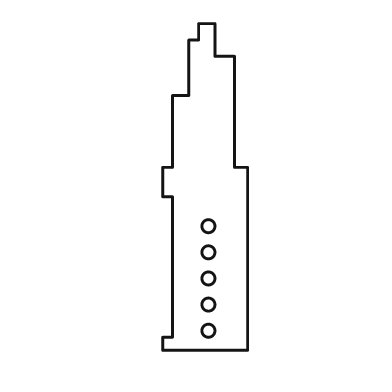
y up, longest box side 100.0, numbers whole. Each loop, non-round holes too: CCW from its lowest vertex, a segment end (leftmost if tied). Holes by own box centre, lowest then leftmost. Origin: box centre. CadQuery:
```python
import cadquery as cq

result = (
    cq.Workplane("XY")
    .moveTo(-13.0, -50.0)
    .lineTo(13.0, -50.0)
    .lineTo(13.0, 6.0)
    .lineTo(9.0, 6.0)
    .lineTo(9.0, 40.0)
    .lineTo(3.0, 40.0)
    .lineTo(3.0, 50.0)
    .lineTo(-2.0, 50.0)
    .lineTo(-2.0, 45.0)
    .lineTo(-5.0, 45.0)
    .lineTo(-5.0, 28.0)
    .lineTo(-10.0, 28.0)
    .lineTo(-10.0, 6.0)
    .lineTo(-13.0, 6.0)
    .lineTo(-13.0, -3.0)
    .lineTo(-10.0, -3.0)
    .lineTo(-10.0, -46.0)
    .lineTo(-13.0, -46.0)
    .close()
    .moveTo(1.0, -44.0)
    .circle(2.0)
    .moveTo(1.0, -36.0)
    .circle(2.0)
    .moveTo(1.0, -28.0)
    .circle(2.0)
    .moveTo(1.0, -20.0)
    .circle(2.0)
    .moveTo(1.0, -12.0)
    .circle(2.0)
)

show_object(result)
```